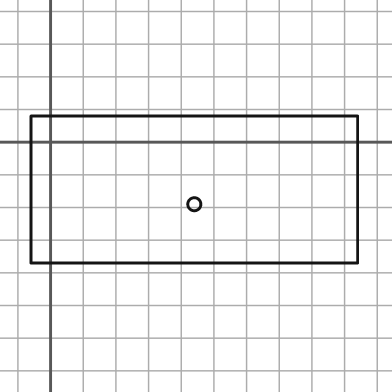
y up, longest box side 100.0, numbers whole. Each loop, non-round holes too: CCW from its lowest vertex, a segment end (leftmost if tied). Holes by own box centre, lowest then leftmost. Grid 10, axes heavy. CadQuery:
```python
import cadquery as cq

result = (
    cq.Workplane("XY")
    .moveTo(-6.0, -37.0)
    .lineTo(94.0, -37.0)
    .lineTo(94.0, 8.0)
    .lineTo(-6.0, 8.0)
    .close()
    .moveTo(44.0, -19.0)
    .circle(2.0)
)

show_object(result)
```